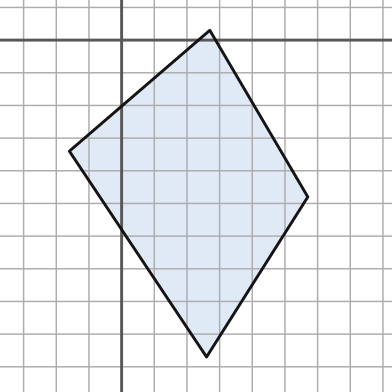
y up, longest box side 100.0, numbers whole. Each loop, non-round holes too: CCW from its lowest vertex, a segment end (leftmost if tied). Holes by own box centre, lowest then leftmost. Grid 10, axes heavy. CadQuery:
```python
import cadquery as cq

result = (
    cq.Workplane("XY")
    .moveTo(26.0, -97.0)
    .lineTo(57.0, -48.0)
    .lineTo(27.0, 3.0)
    .lineTo(-16.0, -34.0)
    .close()
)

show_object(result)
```